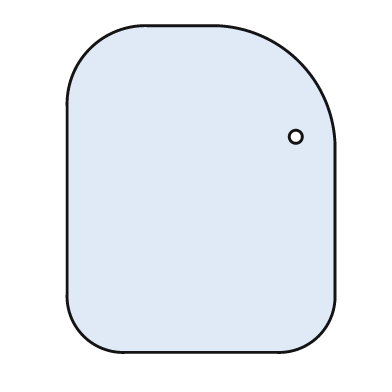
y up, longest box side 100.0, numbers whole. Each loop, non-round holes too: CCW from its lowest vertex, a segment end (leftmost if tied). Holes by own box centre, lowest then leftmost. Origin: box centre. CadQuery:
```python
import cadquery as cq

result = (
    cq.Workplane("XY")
    .moveTo(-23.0, -50.0)
    .lineTo(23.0, -50.0)
    .threePointArc((36.0, -45.0), (41.0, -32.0))
    .lineTo(41.0, 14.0)
    .threePointArc((30.0, 39.0), (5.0, 50.0))
    .lineTo(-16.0, 50.0)
    .threePointArc((-34.0, 43.0), (-41.0, 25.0))
    .lineTo(-41.0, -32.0)
    .threePointArc((-36.0, -45.0), (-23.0, -50.0))
    .close()
    .moveTo(29.0, 16.0)
    .circle(2.0)
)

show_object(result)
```